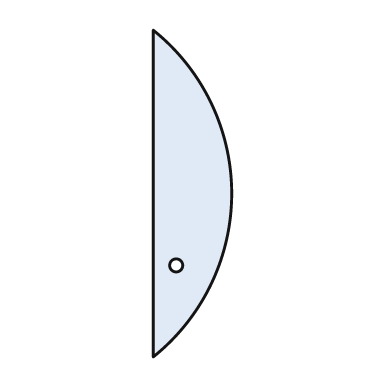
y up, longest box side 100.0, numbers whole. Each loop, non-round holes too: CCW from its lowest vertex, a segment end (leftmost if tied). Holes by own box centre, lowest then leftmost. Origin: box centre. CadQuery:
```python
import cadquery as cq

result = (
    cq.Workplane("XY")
    .moveTo(-12.0, -50.0)
    .threePointArc((12.0, 0.0), (-12.0, 50.0))
    .close()
    .moveTo(-5.0, -22.0)
    .circle(2.0)
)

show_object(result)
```